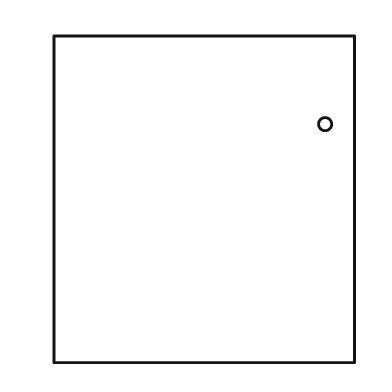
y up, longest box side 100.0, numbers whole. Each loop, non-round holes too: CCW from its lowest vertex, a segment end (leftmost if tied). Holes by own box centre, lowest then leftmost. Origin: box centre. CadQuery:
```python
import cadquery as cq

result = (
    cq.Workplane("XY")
    .moveTo(-46.0, -50.0)
    .lineTo(46.0, -50.0)
    .lineTo(46.0, 50.0)
    .lineTo(-46.0, 50.0)
    .close()
    .moveTo(37.0, 23.0)
    .circle(2.0)
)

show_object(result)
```